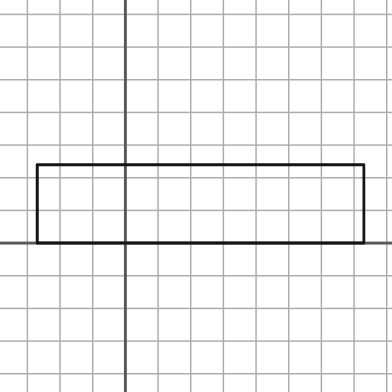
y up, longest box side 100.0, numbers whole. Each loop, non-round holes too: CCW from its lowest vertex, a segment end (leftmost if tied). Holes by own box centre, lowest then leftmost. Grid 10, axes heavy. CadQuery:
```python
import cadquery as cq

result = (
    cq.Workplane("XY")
    .moveTo(-27.0, 0.0)
    .lineTo(73.0, 0.0)
    .lineTo(73.0, 24.0)
    .lineTo(-27.0, 24.0)
    .close()
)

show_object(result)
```